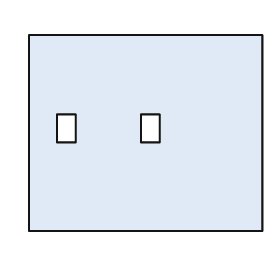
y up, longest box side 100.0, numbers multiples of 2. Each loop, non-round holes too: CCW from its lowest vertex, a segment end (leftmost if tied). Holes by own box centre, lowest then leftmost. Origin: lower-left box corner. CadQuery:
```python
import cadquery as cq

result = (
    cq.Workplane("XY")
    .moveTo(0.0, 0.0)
    .lineTo(100.0, 0.0)
    .lineTo(100.0, 84.0)
    .lineTo(0.0, 84.0)
    .close()
    .moveTo(12.0, 38.0)
    .lineTo(20.0, 38.0)
    .lineTo(20.0, 50.0)
    .lineTo(12.0, 50.0)
    .close()
    .moveTo(48.0, 38.0)
    .lineTo(56.0, 38.0)
    .lineTo(56.0, 50.0)
    .lineTo(48.0, 50.0)
    .close()
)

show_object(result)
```